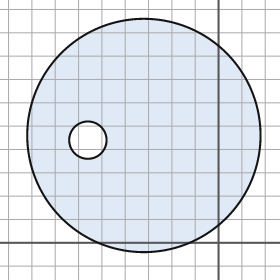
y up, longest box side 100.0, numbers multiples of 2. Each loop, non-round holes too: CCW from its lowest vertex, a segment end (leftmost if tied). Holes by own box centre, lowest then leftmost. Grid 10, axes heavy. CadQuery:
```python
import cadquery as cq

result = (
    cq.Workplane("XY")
    .moveTo(-32.0, 46.0)
    .circle(50.0)
    .moveTo(-56.0, 44.0)
    .circle(8.0)
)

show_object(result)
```